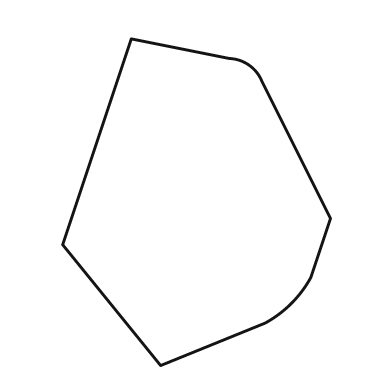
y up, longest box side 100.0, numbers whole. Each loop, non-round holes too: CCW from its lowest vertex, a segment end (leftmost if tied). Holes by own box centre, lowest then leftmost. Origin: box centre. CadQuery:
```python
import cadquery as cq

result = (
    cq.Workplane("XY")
    .moveTo(-11.0, -50.0)
    .lineTo(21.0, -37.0)
    .threePointArc((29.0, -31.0), (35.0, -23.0))
    .lineTo(41.0, -5.0)
    .lineTo(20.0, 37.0)
    .threePointArc((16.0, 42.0), (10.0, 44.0))
    .lineTo(-20.0, 50.0)
    .lineTo(-41.0, -13.0)
    .close()
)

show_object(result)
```